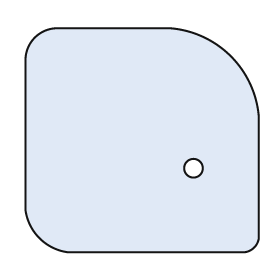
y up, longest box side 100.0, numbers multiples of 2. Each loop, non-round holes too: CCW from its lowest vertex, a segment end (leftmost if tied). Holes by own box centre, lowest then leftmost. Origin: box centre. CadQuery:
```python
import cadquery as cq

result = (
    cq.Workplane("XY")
    .moveTo(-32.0, -48.0)
    .lineTo(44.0, -48.0)
    .threePointArc((48.0, -46.0), (50.0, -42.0))
    .lineTo(50.0, 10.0)
    .threePointArc((38.0, 36.0), (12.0, 48.0))
    .lineTo(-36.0, 48.0)
    .threePointArc((-46.0, 44.0), (-50.0, 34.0))
    .lineTo(-50.0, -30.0)
    .threePointArc((-44.0, -42.0), (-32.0, -48.0))
    .close()
    .moveTo(22.0, -12.0)
    .circle(4.0)
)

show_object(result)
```